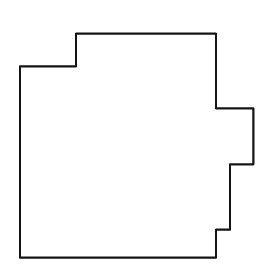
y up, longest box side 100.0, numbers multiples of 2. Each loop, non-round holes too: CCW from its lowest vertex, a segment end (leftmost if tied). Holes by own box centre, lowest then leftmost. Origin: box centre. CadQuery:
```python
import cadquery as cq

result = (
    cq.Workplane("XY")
    .moveTo(-50.0, -48.0)
    .lineTo(34.0, -48.0)
    .lineTo(34.0, -36.0)
    .lineTo(40.0, -36.0)
    .lineTo(40.0, -8.0)
    .lineTo(50.0, -8.0)
    .lineTo(50.0, 16.0)
    .lineTo(34.0, 16.0)
    .lineTo(34.0, 48.0)
    .lineTo(-26.0, 48.0)
    .lineTo(-26.0, 34.0)
    .lineTo(-50.0, 34.0)
    .close()
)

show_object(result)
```